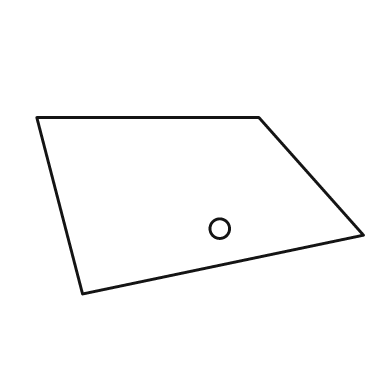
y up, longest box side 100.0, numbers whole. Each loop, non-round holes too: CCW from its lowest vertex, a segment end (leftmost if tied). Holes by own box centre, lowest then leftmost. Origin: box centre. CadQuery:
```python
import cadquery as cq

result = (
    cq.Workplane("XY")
    .moveTo(-36.0, -27.0)
    .lineTo(50.0, -9.0)
    .lineTo(18.0, 27.0)
    .lineTo(-50.0, 27.0)
    .close()
    .moveTo(6.0, -7.0)
    .circle(3.0)
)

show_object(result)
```